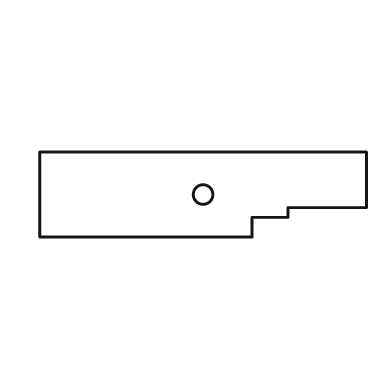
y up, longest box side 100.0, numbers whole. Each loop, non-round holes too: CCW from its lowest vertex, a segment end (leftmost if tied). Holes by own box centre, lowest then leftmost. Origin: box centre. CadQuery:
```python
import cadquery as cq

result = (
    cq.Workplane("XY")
    .moveTo(-50.0, -13.0)
    .lineTo(15.0, -13.0)
    .lineTo(15.0, -7.0)
    .lineTo(26.0, -7.0)
    .lineTo(26.0, -4.0)
    .lineTo(50.0, -4.0)
    .lineTo(50.0, 13.0)
    .lineTo(-50.0, 13.0)
    .close()
    .moveTo(0.0, 0.0)
    .circle(3.0)
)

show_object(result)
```